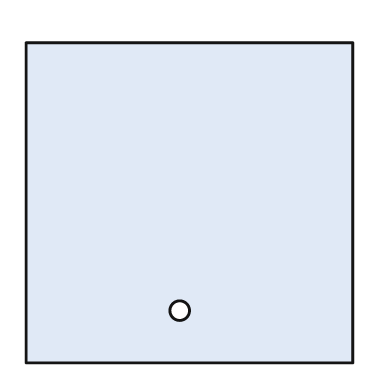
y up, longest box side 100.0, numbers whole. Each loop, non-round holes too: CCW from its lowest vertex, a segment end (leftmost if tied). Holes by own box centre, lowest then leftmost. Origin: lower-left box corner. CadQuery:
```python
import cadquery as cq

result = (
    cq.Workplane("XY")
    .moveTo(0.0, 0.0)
    .lineTo(100.0, 0.0)
    .lineTo(100.0, 98.0)
    .lineTo(0.0, 98.0)
    .close()
    .moveTo(47.0, 16.0)
    .circle(3.0)
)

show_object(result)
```